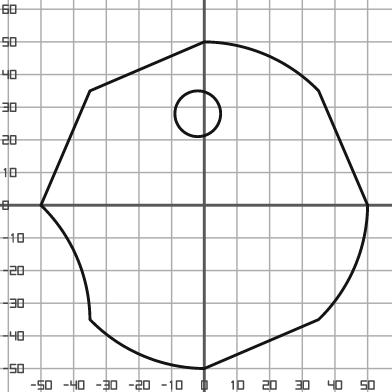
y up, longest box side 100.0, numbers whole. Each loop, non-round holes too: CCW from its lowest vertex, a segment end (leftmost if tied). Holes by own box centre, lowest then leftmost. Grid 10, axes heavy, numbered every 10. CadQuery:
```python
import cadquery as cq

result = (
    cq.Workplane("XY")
    .moveTo(0.0, -50.0)
    .lineTo(35.0, -35.0)
    .threePointArc((46.0, -19.0), (50.0, 0.0))
    .lineTo(35.0, 35.0)
    .threePointArc((19.0, 46.0), (0.0, 50.0))
    .lineTo(-35.0, 35.0)
    .lineTo(-50.0, 0.0)
    .threePointArc((-39.0, -16.0), (-35.0, -35.0))
    .threePointArc((-19.0, -46.0), (0.0, -50.0))
    .close()
    .moveTo(-2.0, 28.0)
    .circle(7.0)
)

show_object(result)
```